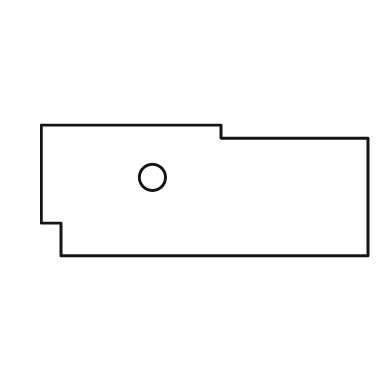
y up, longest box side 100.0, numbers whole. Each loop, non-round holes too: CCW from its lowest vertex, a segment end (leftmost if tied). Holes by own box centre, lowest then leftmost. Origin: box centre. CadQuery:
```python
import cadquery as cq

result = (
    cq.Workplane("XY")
    .moveTo(-44.0, -20.0)
    .lineTo(50.0, -20.0)
    .lineTo(50.0, 16.0)
    .lineTo(5.0, 16.0)
    .lineTo(5.0, 20.0)
    .lineTo(-50.0, 20.0)
    .lineTo(-50.0, -10.0)
    .lineTo(-44.0, -10.0)
    .close()
    .moveTo(-16.0, 4.0)
    .circle(4.0)
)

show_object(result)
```